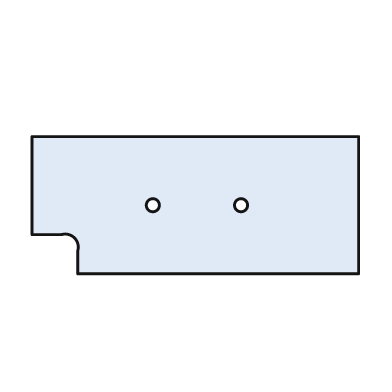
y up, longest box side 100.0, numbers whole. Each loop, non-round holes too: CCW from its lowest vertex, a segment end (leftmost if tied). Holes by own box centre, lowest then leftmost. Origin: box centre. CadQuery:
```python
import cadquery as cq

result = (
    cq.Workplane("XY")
    .moveTo(-36.0, -21.0)
    .lineTo(50.0, -21.0)
    .lineTo(50.0, 21.0)
    .lineTo(-50.0, 21.0)
    .lineTo(-50.0, -9.0)
    .lineTo(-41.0, -9.0)
    .threePointArc((-37.0, -10.0), (-36.0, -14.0))
    .close()
    .moveTo(-13.0, 0.0)
    .circle(2.0)
    .moveTo(14.0, 0.0)
    .circle(2.0)
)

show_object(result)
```